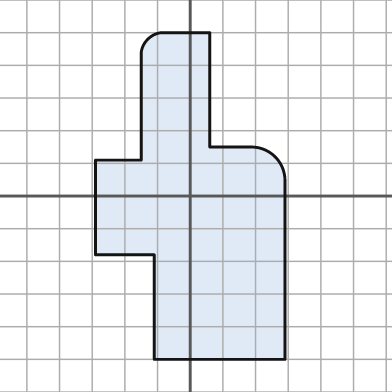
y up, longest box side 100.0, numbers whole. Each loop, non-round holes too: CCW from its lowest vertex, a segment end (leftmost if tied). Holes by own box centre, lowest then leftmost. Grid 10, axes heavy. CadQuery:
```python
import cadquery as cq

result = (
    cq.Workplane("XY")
    .moveTo(-11.0, -50.0)
    .lineTo(29.0, -50.0)
    .lineTo(29.0, 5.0)
    .threePointArc((26.0, 12.0), (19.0, 15.0))
    .lineTo(6.0, 15.0)
    .lineTo(6.0, 50.0)
    .lineTo(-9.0, 50.0)
    .threePointArc((-13.0, 48.0), (-15.0, 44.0))
    .lineTo(-15.0, 11.0)
    .lineTo(-29.0, 11.0)
    .lineTo(-29.0, -18.0)
    .lineTo(-11.0, -18.0)
    .close()
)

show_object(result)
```